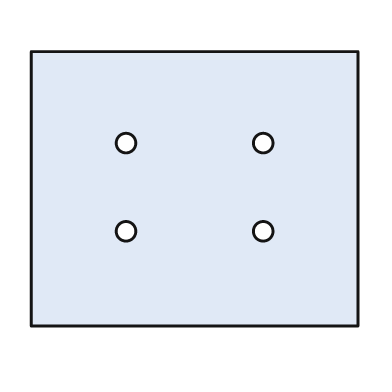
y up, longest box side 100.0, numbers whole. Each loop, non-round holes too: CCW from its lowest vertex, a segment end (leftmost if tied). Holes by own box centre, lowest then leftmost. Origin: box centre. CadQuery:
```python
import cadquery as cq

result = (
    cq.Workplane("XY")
    .moveTo(-50.0, -42.0)
    .lineTo(50.0, -42.0)
    .lineTo(50.0, 42.0)
    .lineTo(-50.0, 42.0)
    .close()
    .moveTo(-21.0, -13.0)
    .circle(3.0)
    .moveTo(21.0, -13.0)
    .circle(3.0)
    .moveTo(-21.0, 14.0)
    .circle(3.0)
    .moveTo(21.0, 14.0)
    .circle(3.0)
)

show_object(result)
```